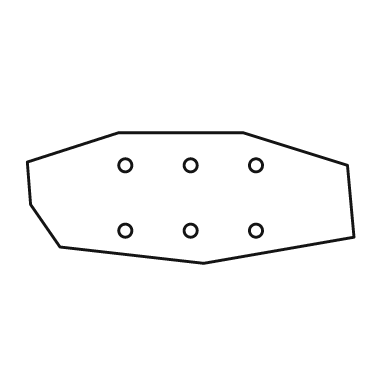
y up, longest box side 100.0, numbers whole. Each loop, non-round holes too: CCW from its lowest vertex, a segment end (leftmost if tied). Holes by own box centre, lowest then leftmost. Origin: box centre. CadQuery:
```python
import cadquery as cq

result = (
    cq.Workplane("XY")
    .moveTo(4.0, -20.0)
    .lineTo(50.0, -12.0)
    .lineTo(48.0, 10.0)
    .lineTo(16.0, 20.0)
    .lineTo(-22.0, 20.0)
    .lineTo(-50.0, 11.0)
    .lineTo(-49.0, -2.0)
    .lineTo(-40.0, -15.0)
    .close()
    .moveTo(-20.0, -10.0)
    .circle(2.0)
    .moveTo(0.0, -10.0)
    .circle(2.0)
    .moveTo(20.0, -10.0)
    .circle(2.0)
    .moveTo(-20.0, 10.0)
    .circle(2.0)
    .moveTo(0.0, 10.0)
    .circle(2.0)
    .moveTo(20.0, 10.0)
    .circle(2.0)
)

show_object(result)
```